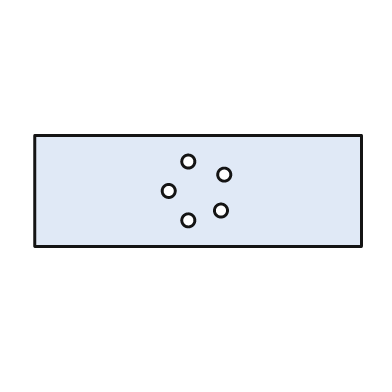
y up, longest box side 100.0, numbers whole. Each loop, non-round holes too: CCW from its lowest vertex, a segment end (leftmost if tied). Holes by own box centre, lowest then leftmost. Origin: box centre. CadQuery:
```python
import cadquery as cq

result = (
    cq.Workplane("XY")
    .moveTo(-50.0, -17.0)
    .lineTo(50.0, -17.0)
    .lineTo(50.0, 17.0)
    .lineTo(-50.0, 17.0)
    .close()
    .moveTo(-3.0, -9.0)
    .circle(2.0)
    .moveTo(7.0, -6.0)
    .circle(2.0)
    .moveTo(-9.0, 0.0)
    .circle(2.0)
    .moveTo(8.0, 5.0)
    .circle(2.0)
    .moveTo(-3.0, 9.0)
    .circle(2.0)
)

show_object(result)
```